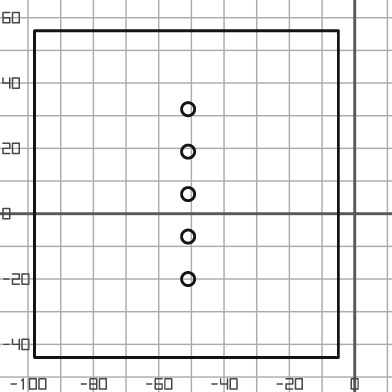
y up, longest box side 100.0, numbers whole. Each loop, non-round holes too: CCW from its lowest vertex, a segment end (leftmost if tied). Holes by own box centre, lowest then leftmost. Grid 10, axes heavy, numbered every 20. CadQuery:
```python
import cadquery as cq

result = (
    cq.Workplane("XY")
    .moveTo(-98.0, -44.0)
    .lineTo(-5.0, -44.0)
    .lineTo(-5.0, 56.0)
    .lineTo(-98.0, 56.0)
    .close()
    .moveTo(-51.0, -20.0)
    .circle(2.0)
    .moveTo(-51.0, -7.0)
    .circle(2.0)
    .moveTo(-51.0, 6.0)
    .circle(2.0)
    .moveTo(-51.0, 19.0)
    .circle(2.0)
    .moveTo(-51.0, 32.0)
    .circle(2.0)
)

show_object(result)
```